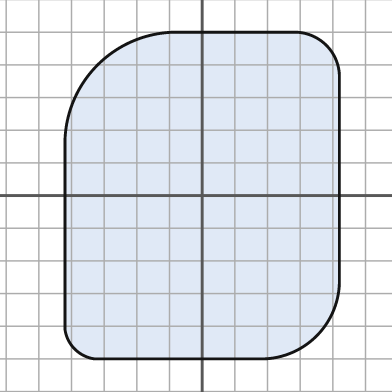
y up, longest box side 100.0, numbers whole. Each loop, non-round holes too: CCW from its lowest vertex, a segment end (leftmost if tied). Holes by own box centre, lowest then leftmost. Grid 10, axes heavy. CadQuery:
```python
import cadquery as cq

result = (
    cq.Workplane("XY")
    .moveTo(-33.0, -50.0)
    .lineTo(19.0, -50.0)
    .threePointArc((35.0, -43.0), (42.0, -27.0))
    .lineTo(42.0, 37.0)
    .threePointArc((38.0, 46.0), (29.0, 50.0))
    .lineTo(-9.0, 50.0)
    .threePointArc((-32.0, 40.0), (-42.0, 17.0))
    .lineTo(-42.0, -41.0)
    .threePointArc((-39.0, -47.0), (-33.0, -50.0))
    .close()
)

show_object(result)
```